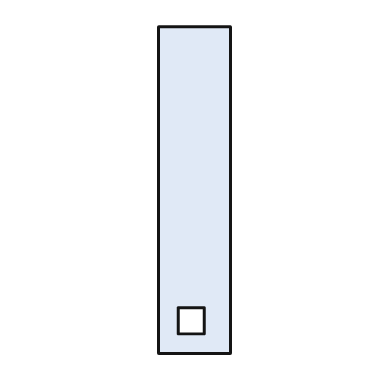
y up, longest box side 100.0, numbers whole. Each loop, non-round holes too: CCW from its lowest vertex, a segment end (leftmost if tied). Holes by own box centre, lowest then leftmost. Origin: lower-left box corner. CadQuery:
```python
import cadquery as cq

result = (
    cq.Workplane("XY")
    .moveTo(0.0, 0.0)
    .lineTo(22.0, 0.0)
    .lineTo(22.0, 100.0)
    .lineTo(0.0, 100.0)
    .close()
    .moveTo(6.0, 6.0)
    .lineTo(14.0, 6.0)
    .lineTo(14.0, 14.0)
    .lineTo(6.0, 14.0)
    .close()
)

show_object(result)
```